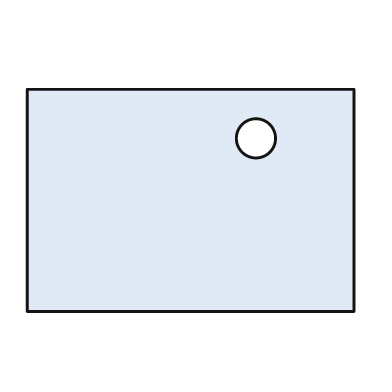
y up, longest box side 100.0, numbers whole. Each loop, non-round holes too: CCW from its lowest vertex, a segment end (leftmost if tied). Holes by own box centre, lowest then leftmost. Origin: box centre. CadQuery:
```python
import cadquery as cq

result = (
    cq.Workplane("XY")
    .moveTo(-50.0, -34.0)
    .lineTo(50.0, -34.0)
    .lineTo(50.0, 34.0)
    .lineTo(-50.0, 34.0)
    .close()
    .moveTo(20.0, 19.0)
    .circle(6.0)
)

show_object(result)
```